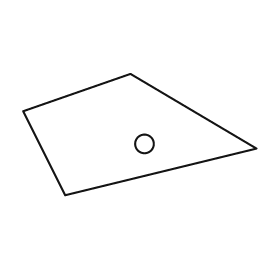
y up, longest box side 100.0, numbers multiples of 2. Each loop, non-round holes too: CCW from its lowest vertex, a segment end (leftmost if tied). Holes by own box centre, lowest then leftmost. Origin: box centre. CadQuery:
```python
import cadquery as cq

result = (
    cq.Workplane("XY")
    .moveTo(-32.0, -26.0)
    .lineTo(50.0, -6.0)
    .lineTo(-4.0, 26.0)
    .lineTo(-50.0, 10.0)
    .close()
    .moveTo(2.0, -4.0)
    .circle(4.0)
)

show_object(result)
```